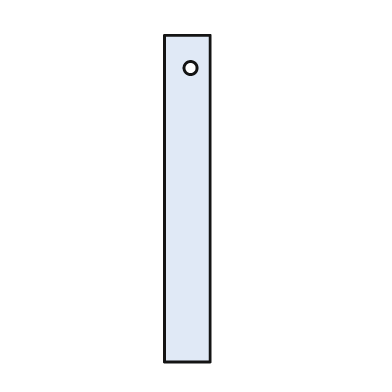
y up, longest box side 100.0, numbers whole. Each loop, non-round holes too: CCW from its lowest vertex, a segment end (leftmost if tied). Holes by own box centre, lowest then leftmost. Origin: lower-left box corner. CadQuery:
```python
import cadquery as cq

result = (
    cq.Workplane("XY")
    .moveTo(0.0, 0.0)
    .lineTo(14.0, 0.0)
    .lineTo(14.0, 100.0)
    .lineTo(0.0, 100.0)
    .close()
    .moveTo(8.0, 90.0)
    .circle(2.0)
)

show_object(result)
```